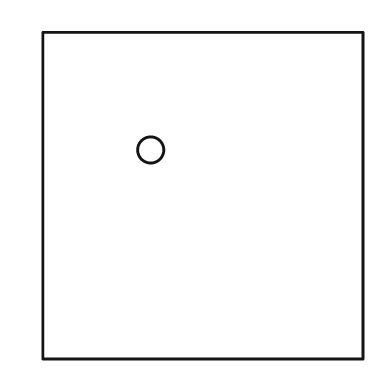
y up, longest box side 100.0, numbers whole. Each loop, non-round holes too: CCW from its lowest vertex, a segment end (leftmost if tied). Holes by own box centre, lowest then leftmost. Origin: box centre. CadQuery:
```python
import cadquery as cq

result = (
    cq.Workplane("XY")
    .moveTo(-49.0, -50.0)
    .lineTo(49.0, -50.0)
    .lineTo(49.0, 50.0)
    .lineTo(-49.0, 50.0)
    .close()
    .moveTo(-16.0, 14.0)
    .circle(4.0)
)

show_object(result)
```